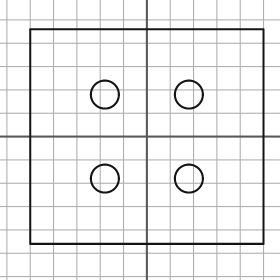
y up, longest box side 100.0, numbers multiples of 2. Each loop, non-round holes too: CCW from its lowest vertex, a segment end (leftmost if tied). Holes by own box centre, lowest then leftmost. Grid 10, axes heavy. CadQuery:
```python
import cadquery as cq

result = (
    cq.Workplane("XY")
    .moveTo(-50.0, -46.0)
    .lineTo(50.0, -46.0)
    .lineTo(50.0, 46.0)
    .lineTo(-50.0, 46.0)
    .close()
    .moveTo(-18.0, -18.0)
    .circle(6.0)
    .moveTo(18.0, -18.0)
    .circle(6.0)
    .moveTo(-18.0, 18.0)
    .circle(6.0)
    .moveTo(18.0, 18.0)
    .circle(6.0)
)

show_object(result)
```